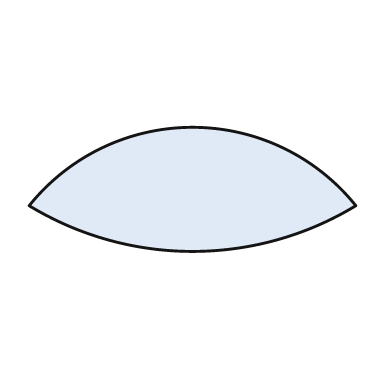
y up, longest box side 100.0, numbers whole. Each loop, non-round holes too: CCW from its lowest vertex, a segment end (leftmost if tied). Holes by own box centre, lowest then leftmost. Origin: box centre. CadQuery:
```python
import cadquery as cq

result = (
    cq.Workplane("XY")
    .moveTo(-50.0, -5.0)
    .threePointArc((0.0, -19.0), (50.0, -5.0))
    .threePointArc((0.0, 19.0), (-50.0, -5.0))
    .close()
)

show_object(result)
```